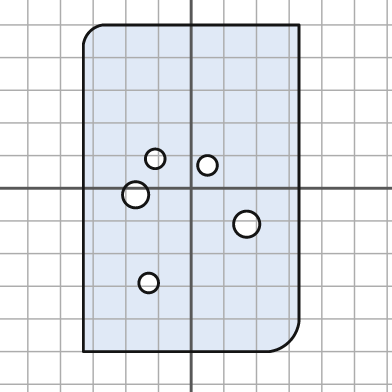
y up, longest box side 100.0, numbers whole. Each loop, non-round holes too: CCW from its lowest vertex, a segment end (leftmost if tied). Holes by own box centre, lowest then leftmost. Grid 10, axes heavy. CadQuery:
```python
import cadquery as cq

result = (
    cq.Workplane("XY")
    .moveTo(-33.0, -50.0)
    .lineTo(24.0, -50.0)
    .threePointArc((30.0, -47.0), (33.0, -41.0))
    .lineTo(33.0, 50.0)
    .lineTo(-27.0, 50.0)
    .threePointArc((-31.0, 48.0), (-33.0, 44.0))
    .close()
    .moveTo(-13.0, -29.0)
    .circle(3.0)
    .moveTo(17.0, -11.0)
    .circle(4.0)
    .moveTo(-17.0, -2.0)
    .circle(4.0)
    .moveTo(5.0, 7.0)
    .circle(3.0)
    .moveTo(-11.0, 9.0)
    .circle(3.0)
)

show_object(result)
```